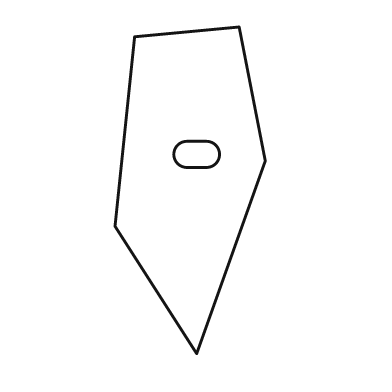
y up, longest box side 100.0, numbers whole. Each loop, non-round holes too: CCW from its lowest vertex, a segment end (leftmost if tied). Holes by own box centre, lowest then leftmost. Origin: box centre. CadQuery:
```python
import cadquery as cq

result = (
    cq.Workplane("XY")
    .moveTo(2.0, -50.0)
    .lineTo(23.0, 9.0)
    .lineTo(15.0, 50.0)
    .lineTo(-17.0, 47.0)
    .lineTo(-23.0, -11.0)
    .close()
    .moveTo(-1.0, 7.0)
    .lineTo(5.0, 7.0)
    .threePointArc((9.0, 11.0), (5.0, 15.0))
    .lineTo(-1.0, 15.0)
    .threePointArc((-5.0, 11.0), (-1.0, 7.0))
    .close()
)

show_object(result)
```